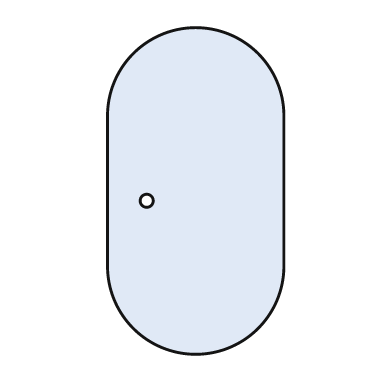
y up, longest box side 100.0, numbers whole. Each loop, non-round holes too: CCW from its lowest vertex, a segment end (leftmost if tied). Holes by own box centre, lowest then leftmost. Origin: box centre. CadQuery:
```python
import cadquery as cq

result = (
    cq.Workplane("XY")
    .moveTo(-27.0, -23.0)
    .threePointArc((0.0, -50.0), (27.0, -23.0))
    .lineTo(27.0, 23.0)
    .threePointArc((0.0, 50.0), (-27.0, 23.0))
    .close()
    .moveTo(-15.0, -3.0)
    .circle(2.0)
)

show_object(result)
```